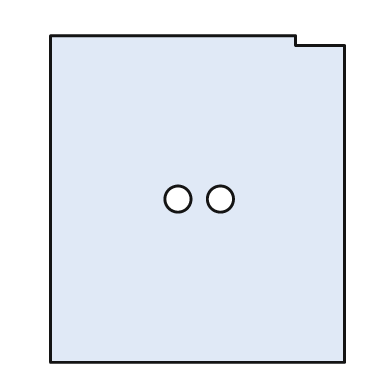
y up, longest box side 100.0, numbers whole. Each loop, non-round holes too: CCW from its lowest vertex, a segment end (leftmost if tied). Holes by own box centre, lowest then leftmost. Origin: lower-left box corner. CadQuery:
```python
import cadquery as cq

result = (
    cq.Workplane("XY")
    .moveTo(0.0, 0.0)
    .lineTo(90.0, 0.0)
    .lineTo(90.0, 97.0)
    .lineTo(75.0, 97.0)
    .lineTo(75.0, 100.0)
    .lineTo(0.0, 100.0)
    .close()
    .moveTo(39.0, 50.0)
    .circle(4.0)
    .moveTo(52.0, 50.0)
    .circle(4.0)
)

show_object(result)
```